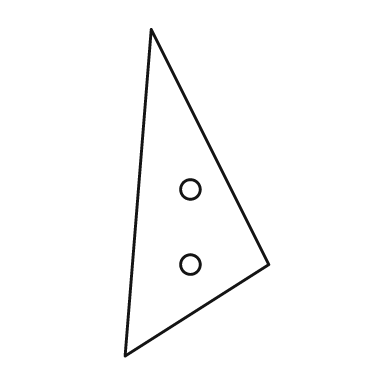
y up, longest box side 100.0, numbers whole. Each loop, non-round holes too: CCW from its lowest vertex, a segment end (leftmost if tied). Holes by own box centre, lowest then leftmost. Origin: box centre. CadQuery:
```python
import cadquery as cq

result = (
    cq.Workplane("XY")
    .moveTo(-22.0, -50.0)
    .lineTo(22.0, -22.0)
    .lineTo(-14.0, 50.0)
    .close()
    .moveTo(-2.0, -22.0)
    .circle(3.0)
    .moveTo(-2.0, 1.0)
    .circle(3.0)
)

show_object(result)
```